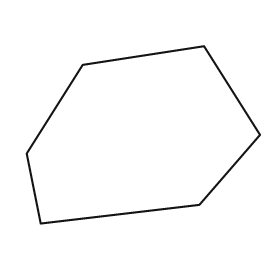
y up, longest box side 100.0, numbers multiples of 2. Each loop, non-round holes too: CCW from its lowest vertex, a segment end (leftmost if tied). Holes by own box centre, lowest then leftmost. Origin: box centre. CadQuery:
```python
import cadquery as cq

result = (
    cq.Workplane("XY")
    .moveTo(-44.0, -38.0)
    .lineTo(24.0, -30.0)
    .lineTo(50.0, 0.0)
    .lineTo(26.0, 38.0)
    .lineTo(-26.0, 30.0)
    .lineTo(-50.0, -8.0)
    .close()
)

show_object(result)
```